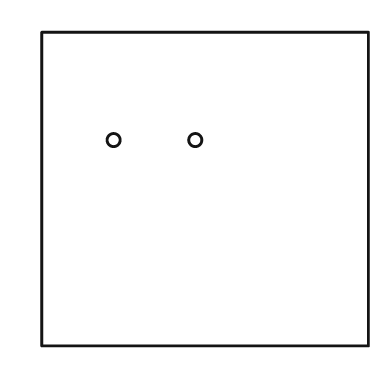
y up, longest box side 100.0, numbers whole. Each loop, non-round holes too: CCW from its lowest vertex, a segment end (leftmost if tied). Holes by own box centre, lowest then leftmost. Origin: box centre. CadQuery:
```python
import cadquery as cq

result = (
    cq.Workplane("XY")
    .moveTo(-50.0, -48.0)
    .lineTo(50.0, -48.0)
    .lineTo(50.0, 48.0)
    .lineTo(-50.0, 48.0)
    .close()
    .moveTo(-28.0, 15.0)
    .circle(2.0)
    .moveTo(-3.0, 15.0)
    .circle(2.0)
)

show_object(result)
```